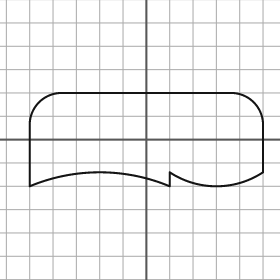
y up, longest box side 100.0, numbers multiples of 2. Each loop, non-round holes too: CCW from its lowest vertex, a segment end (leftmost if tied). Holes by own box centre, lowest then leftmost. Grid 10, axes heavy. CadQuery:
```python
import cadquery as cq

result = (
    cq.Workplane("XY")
    .moveTo(-50.0, -20.0)
    .threePointArc((-20.0, -14.0), (10.0, -20.0))
    .lineTo(10.0, -14.0)
    .threePointArc((30.0, -20.0), (50.0, -14.0))
    .lineTo(50.0, 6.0)
    .threePointArc((46.0, 16.0), (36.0, 20.0))
    .lineTo(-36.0, 20.0)
    .threePointArc((-46.0, 16.0), (-50.0, 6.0))
    .close()
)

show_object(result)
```